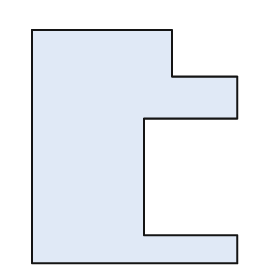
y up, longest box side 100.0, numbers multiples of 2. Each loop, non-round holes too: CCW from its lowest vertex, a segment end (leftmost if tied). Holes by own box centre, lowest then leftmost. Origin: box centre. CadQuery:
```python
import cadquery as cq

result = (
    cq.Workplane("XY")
    .moveTo(-44.0, -50.0)
    .lineTo(44.0, -50.0)
    .lineTo(44.0, -38.0)
    .lineTo(4.0, -38.0)
    .lineTo(4.0, 12.0)
    .lineTo(44.0, 12.0)
    .lineTo(44.0, 30.0)
    .lineTo(16.0, 30.0)
    .lineTo(16.0, 50.0)
    .lineTo(-44.0, 50.0)
    .close()
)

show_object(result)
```